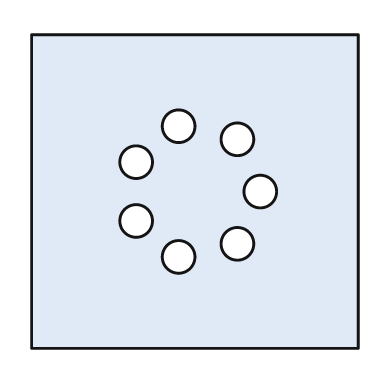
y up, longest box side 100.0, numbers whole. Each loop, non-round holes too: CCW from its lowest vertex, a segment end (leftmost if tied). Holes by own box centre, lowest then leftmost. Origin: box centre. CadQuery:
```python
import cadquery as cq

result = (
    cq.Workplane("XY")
    .moveTo(-50.0, -48.0)
    .lineTo(50.0, -48.0)
    .lineTo(50.0, 48.0)
    .lineTo(-50.0, 48.0)
    .close()
    .moveTo(-5.0, -20.0)
    .circle(5.0)
    .moveTo(13.0, -16.0)
    .circle(5.0)
    .moveTo(-18.0, -9.0)
    .circle(5.0)
    .moveTo(20.0, 0.0)
    .circle(5.0)
    .moveTo(-18.0, 9.0)
    .circle(5.0)
    .moveTo(13.0, 16.0)
    .circle(5.0)
    .moveTo(-5.0, 20.0)
    .circle(5.0)
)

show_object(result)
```